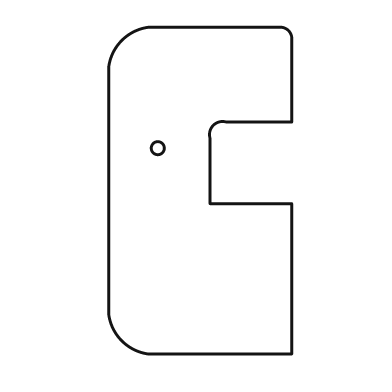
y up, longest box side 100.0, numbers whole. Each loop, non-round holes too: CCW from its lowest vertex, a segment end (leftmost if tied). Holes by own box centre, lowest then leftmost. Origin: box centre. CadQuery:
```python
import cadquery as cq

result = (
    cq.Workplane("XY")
    .moveTo(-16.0, -50.0)
    .lineTo(28.0, -50.0)
    .lineTo(28.0, -4.0)
    .lineTo(3.0, -4.0)
    .lineTo(3.0, 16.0)
    .threePointArc((4.0, 20.0), (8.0, 21.0))
    .lineTo(28.0, 21.0)
    .lineTo(28.0, 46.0)
    .threePointArc((27.0, 49.0), (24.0, 50.0))
    .lineTo(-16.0, 50.0)
    .threePointArc((-24.0, 46.0), (-28.0, 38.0))
    .lineTo(-28.0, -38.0)
    .threePointArc((-24.0, -46.0), (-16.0, -50.0))
    .close()
    .moveTo(-13.0, 13.0)
    .circle(2.0)
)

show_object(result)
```